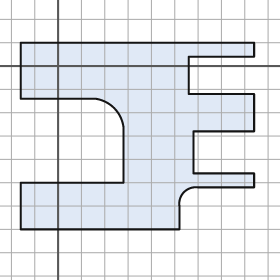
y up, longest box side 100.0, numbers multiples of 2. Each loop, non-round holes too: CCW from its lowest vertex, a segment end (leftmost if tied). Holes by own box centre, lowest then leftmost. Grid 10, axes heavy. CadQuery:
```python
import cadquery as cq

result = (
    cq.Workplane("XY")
    .moveTo(-16.0, -70.0)
    .lineTo(52.0, -70.0)
    .lineTo(52.0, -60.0)
    .threePointArc((54.0, -54.0), (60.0, -52.0))
    .lineTo(84.0, -52.0)
    .lineTo(84.0, -46.0)
    .lineTo(58.0, -46.0)
    .lineTo(58.0, -28.0)
    .lineTo(84.0, -28.0)
    .lineTo(84.0, -12.0)
    .lineTo(56.0, -12.0)
    .lineTo(56.0, 4.0)
    .lineTo(84.0, 4.0)
    .lineTo(84.0, 10.0)
    .lineTo(-16.0, 10.0)
    .lineTo(-16.0, -14.0)
    .lineTo(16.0, -14.0)
    .threePointArc((24.0, -18.0), (28.0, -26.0))
    .lineTo(28.0, -50.0)
    .lineTo(-16.0, -50.0)
    .close()
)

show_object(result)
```